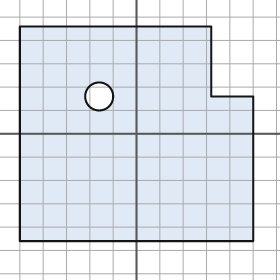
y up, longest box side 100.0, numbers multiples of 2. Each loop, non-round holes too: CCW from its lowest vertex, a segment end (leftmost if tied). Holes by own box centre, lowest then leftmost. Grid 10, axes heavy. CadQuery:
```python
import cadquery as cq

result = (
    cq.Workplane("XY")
    .moveTo(-50.0, -46.0)
    .lineTo(50.0, -46.0)
    .lineTo(50.0, 16.0)
    .lineTo(32.0, 16.0)
    .lineTo(32.0, 46.0)
    .lineTo(-50.0, 46.0)
    .close()
    .moveTo(-16.0, 16.0)
    .circle(6.0)
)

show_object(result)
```